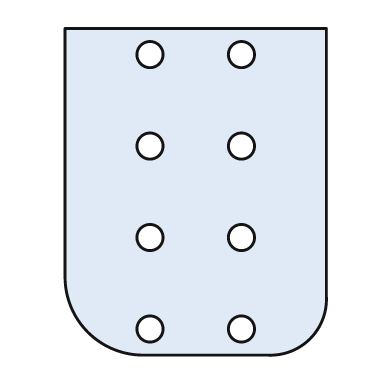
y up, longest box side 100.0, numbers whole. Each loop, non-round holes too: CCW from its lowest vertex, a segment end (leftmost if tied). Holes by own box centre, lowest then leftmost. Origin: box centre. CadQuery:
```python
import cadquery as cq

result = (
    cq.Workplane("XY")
    .moveTo(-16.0, -50.0)
    .lineTo(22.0, -50.0)
    .threePointArc((35.0, -45.0), (40.0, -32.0))
    .lineTo(40.0, 50.0)
    .lineTo(-40.0, 50.0)
    .lineTo(-40.0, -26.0)
    .threePointArc((-33.0, -43.0), (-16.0, -50.0))
    .close()
    .moveTo(-14.0, -42.0)
    .circle(4.0)
    .moveTo(14.0, -42.0)
    .circle(4.0)
    .moveTo(-14.0, -14.0)
    .circle(4.0)
    .moveTo(14.0, -14.0)
    .circle(4.0)
    .moveTo(-14.0, 14.0)
    .circle(4.0)
    .moveTo(14.0, 14.0)
    .circle(4.0)
    .moveTo(-14.0, 42.0)
    .circle(4.0)
    .moveTo(14.0, 42.0)
    .circle(4.0)
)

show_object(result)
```